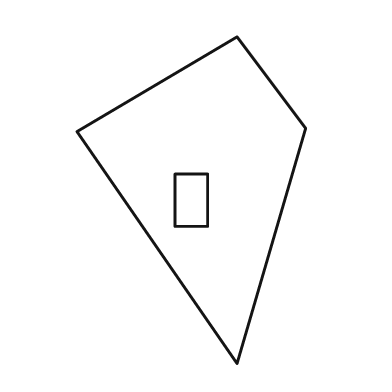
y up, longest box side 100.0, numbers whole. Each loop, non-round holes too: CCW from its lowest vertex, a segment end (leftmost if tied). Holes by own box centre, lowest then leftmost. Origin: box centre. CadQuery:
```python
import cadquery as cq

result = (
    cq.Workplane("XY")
    .moveTo(14.0, -50.0)
    .lineTo(35.0, 22.0)
    .lineTo(14.0, 50.0)
    .lineTo(-35.0, 21.0)
    .close()
    .moveTo(-5.0, -8.0)
    .lineTo(5.0, -8.0)
    .lineTo(5.0, 8.0)
    .lineTo(-5.0, 8.0)
    .close()
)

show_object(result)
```